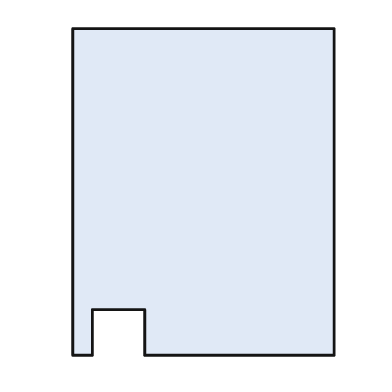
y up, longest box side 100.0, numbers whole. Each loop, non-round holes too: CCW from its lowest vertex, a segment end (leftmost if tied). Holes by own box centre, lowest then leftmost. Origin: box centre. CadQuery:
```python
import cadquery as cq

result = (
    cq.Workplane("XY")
    .moveTo(-40.0, -50.0)
    .lineTo(-34.0, -50.0)
    .lineTo(-34.0, -36.0)
    .lineTo(-18.0, -36.0)
    .lineTo(-18.0, -50.0)
    .lineTo(40.0, -50.0)
    .lineTo(40.0, 50.0)
    .lineTo(-40.0, 50.0)
    .close()
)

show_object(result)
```